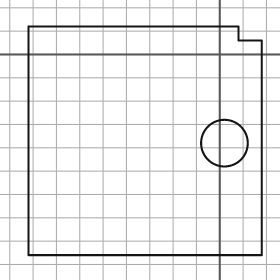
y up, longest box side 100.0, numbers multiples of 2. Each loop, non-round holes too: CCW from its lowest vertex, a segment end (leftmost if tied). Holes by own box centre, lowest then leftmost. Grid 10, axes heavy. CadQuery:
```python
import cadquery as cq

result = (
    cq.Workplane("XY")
    .moveTo(-82.0, -86.0)
    .lineTo(18.0, -86.0)
    .lineTo(18.0, 6.0)
    .lineTo(8.0, 6.0)
    .lineTo(8.0, 12.0)
    .lineTo(-82.0, 12.0)
    .close()
    .moveTo(2.0, -38.0)
    .circle(10.0)
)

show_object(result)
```